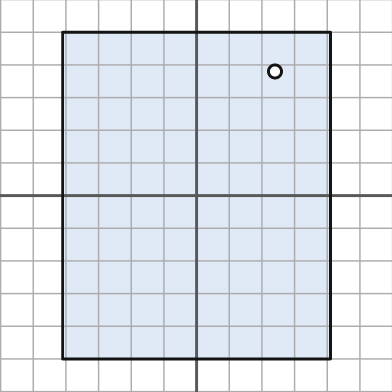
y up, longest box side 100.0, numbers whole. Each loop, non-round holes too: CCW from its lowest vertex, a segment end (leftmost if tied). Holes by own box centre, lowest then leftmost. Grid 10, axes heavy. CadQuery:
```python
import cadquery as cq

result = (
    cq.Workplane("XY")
    .moveTo(-41.0, -50.0)
    .lineTo(41.0, -50.0)
    .lineTo(41.0, 50.0)
    .lineTo(-41.0, 50.0)
    .close()
    .moveTo(24.0, 38.0)
    .circle(2.0)
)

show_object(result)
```